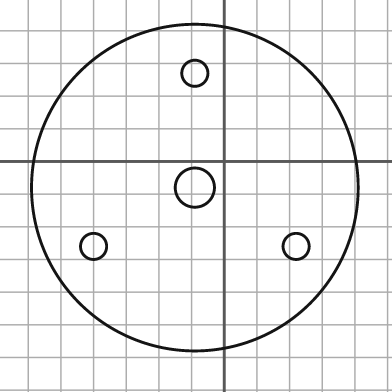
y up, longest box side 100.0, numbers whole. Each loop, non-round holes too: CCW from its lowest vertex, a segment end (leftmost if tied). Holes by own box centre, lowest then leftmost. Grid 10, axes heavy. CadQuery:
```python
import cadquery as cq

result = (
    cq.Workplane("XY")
    .moveTo(-9.0, -8.0)
    .circle(50.0)
    .moveTo(-40.0, -26.0)
    .circle(4.0)
    .moveTo(22.0, -26.0)
    .circle(4.0)
    .moveTo(-9.0, -8.0)
    .circle(6.0)
    .moveTo(-9.0, 27.0)
    .circle(4.0)
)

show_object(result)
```